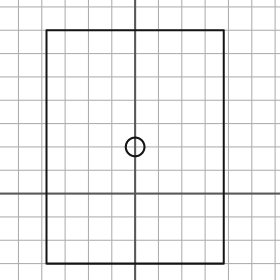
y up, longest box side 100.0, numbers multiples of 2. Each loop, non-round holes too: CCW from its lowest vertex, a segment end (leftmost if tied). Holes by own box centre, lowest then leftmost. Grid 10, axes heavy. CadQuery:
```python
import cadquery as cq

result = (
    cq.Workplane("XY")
    .moveTo(-38.0, -30.0)
    .lineTo(38.0, -30.0)
    .lineTo(38.0, 70.0)
    .lineTo(-38.0, 70.0)
    .close()
    .moveTo(0.0, 20.0)
    .circle(4.0)
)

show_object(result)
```